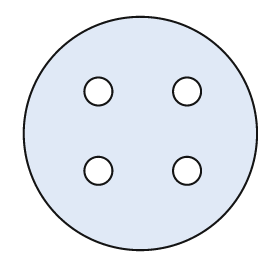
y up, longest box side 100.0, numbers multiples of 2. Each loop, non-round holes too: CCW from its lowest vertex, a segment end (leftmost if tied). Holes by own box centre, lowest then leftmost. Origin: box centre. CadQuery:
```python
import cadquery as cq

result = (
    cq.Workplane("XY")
    .moveTo(0.0, 0.0)
    .circle(50.0)
    .moveTo(-18.0, -16.0)
    .circle(6.0)
    .moveTo(20.0, -16.0)
    .circle(6.0)
    .moveTo(-18.0, 18.0)
    .circle(6.0)
    .moveTo(20.0, 18.0)
    .circle(6.0)
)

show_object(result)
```